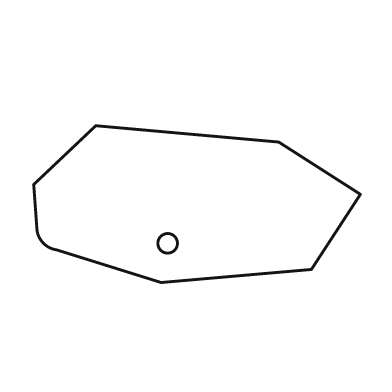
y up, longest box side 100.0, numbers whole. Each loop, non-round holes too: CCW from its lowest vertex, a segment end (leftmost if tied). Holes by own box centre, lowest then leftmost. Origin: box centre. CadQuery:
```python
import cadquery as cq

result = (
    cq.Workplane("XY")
    .moveTo(-11.0, -24.0)
    .lineTo(35.0, -20.0)
    .lineTo(50.0, 3.0)
    .lineTo(25.0, 19.0)
    .lineTo(-31.0, 24.0)
    .lineTo(-50.0, 6.0)
    .lineTo(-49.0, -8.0)
    .threePointArc((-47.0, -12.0), (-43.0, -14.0))
    .close()
    .moveTo(-9.0, -12.0)
    .circle(3.0)
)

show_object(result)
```